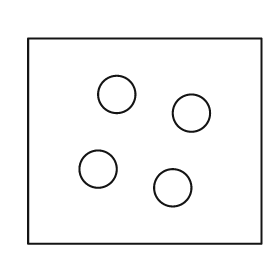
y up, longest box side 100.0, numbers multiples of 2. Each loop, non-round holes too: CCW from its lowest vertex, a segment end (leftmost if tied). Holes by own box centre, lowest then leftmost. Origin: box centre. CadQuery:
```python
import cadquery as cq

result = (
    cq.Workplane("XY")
    .moveTo(-50.0, -44.0)
    .lineTo(50.0, -44.0)
    .lineTo(50.0, 44.0)
    .lineTo(-50.0, 44.0)
    .close()
    .moveTo(12.0, -20.0)
    .circle(8.0)
    .moveTo(-20.0, -12.0)
    .circle(8.0)
    .moveTo(20.0, 12.0)
    .circle(8.0)
    .moveTo(-12.0, 20.0)
    .circle(8.0)
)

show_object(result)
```